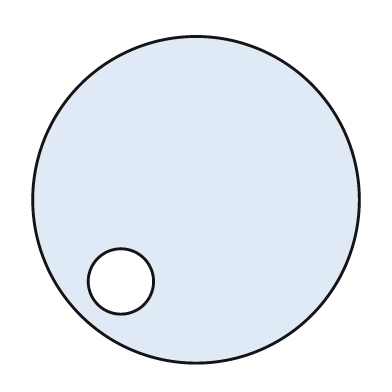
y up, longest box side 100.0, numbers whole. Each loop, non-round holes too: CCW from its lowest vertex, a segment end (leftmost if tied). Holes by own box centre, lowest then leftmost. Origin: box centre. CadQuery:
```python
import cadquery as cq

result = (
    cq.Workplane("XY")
    .moveTo(0.0, 0.0)
    .circle(50.0)
    .moveTo(-23.0, -25.0)
    .circle(10.0)
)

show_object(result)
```